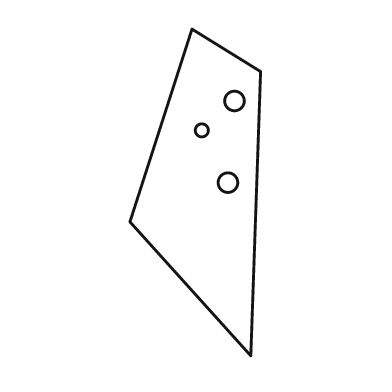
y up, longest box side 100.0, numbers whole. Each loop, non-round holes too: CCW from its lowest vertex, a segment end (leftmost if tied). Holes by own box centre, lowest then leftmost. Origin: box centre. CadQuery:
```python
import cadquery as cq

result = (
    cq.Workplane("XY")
    .moveTo(17.0, -50.0)
    .lineTo(20.0, 37.0)
    .lineTo(-1.0, 50.0)
    .lineTo(-20.0, -9.0)
    .close()
    .moveTo(10.0, 3.0)
    .circle(3.0)
    .moveTo(2.0, 19.0)
    .circle(2.0)
    .moveTo(12.0, 28.0)
    .circle(3.0)
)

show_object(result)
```